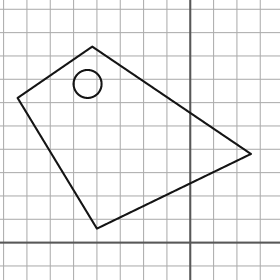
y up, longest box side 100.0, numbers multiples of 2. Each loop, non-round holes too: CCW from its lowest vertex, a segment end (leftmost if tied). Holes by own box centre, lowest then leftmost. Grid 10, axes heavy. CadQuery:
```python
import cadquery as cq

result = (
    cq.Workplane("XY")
    .moveTo(-40.0, 6.0)
    .lineTo(26.0, 38.0)
    .lineTo(-42.0, 84.0)
    .lineTo(-74.0, 62.0)
    .close()
    .moveTo(-44.0, 68.0)
    .circle(6.0)
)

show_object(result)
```